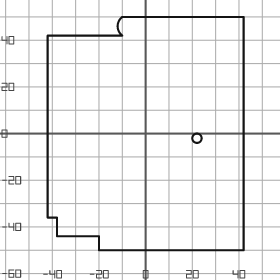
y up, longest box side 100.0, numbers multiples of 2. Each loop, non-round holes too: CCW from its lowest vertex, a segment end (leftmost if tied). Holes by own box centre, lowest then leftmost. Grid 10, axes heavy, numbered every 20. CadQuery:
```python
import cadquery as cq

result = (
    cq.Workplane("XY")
    .moveTo(-20.0, -50.0)
    .lineTo(42.0, -50.0)
    .lineTo(42.0, 50.0)
    .lineTo(-10.0, 50.0)
    .threePointArc((-12.0, 46.0), (-10.0, 42.0))
    .lineTo(-42.0, 42.0)
    .lineTo(-42.0, -36.0)
    .lineTo(-38.0, -36.0)
    .lineTo(-38.0, -44.0)
    .lineTo(-20.0, -44.0)
    .close()
    .moveTo(22.0, -2.0)
    .circle(2.0)
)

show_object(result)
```